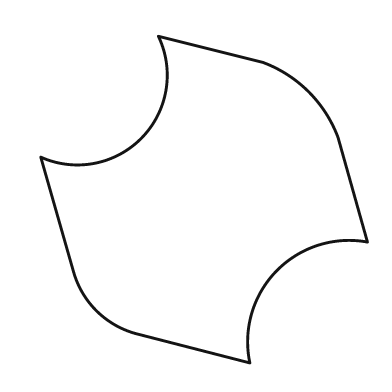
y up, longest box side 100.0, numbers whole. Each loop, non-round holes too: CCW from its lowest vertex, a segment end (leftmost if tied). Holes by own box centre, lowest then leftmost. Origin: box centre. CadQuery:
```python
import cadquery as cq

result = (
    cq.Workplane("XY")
    .moveTo(14.0, -50.0)
    .threePointArc((22.0, -22.0), (50.0, -13.0))
    .lineTo(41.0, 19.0)
    .threePointArc((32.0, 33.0), (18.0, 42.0))
    .lineTo(-14.0, 50.0)
    .threePointArc((-19.0, 19.0), (-50.0, 13.0))
    .lineTo(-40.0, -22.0)
    .threePointArc((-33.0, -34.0), (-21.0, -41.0))
    .close()
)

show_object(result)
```